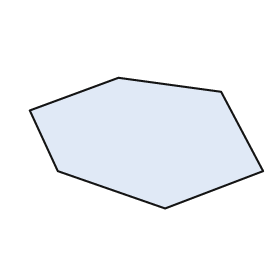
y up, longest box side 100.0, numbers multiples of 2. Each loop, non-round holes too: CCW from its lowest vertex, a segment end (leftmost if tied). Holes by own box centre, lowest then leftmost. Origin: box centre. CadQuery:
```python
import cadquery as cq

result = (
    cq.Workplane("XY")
    .moveTo(8.0, -28.0)
    .lineTo(50.0, -12.0)
    .lineTo(32.0, 22.0)
    .lineTo(-12.0, 28.0)
    .lineTo(-50.0, 14.0)
    .lineTo(-38.0, -12.0)
    .close()
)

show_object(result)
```